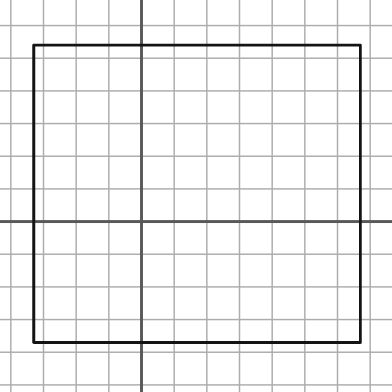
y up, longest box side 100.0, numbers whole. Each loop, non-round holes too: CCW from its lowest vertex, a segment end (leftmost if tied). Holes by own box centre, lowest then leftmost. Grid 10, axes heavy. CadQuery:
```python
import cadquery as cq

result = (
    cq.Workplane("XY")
    .moveTo(-33.0, -37.0)
    .lineTo(67.0, -37.0)
    .lineTo(67.0, 54.0)
    .lineTo(-33.0, 54.0)
    .close()
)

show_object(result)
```